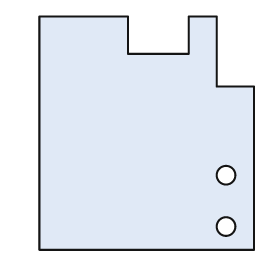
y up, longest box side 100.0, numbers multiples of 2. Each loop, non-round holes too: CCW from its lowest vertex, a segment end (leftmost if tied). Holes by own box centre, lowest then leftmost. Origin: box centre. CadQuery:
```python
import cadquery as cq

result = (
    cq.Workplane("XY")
    .moveTo(-46.0, -50.0)
    .lineTo(46.0, -50.0)
    .lineTo(46.0, 20.0)
    .lineTo(30.0, 20.0)
    .lineTo(30.0, 50.0)
    .lineTo(18.0, 50.0)
    .lineTo(18.0, 34.0)
    .lineTo(-8.0, 34.0)
    .lineTo(-8.0, 50.0)
    .lineTo(-46.0, 50.0)
    .close()
    .moveTo(34.0, -40.0)
    .circle(4.0)
    .moveTo(34.0, -18.0)
    .circle(4.0)
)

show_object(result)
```